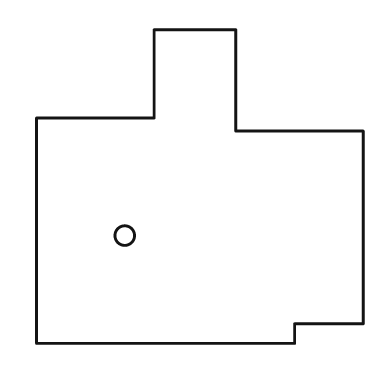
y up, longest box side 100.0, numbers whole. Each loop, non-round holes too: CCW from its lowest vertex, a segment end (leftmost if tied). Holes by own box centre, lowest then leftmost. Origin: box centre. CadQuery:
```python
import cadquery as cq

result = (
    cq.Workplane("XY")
    .moveTo(-50.0, -48.0)
    .lineTo(29.0, -48.0)
    .lineTo(29.0, -42.0)
    .lineTo(50.0, -42.0)
    .lineTo(50.0, 17.0)
    .lineTo(11.0, 17.0)
    .lineTo(11.0, 48.0)
    .lineTo(-14.0, 48.0)
    .lineTo(-14.0, 21.0)
    .lineTo(-50.0, 21.0)
    .close()
    .moveTo(-23.0, -15.0)
    .circle(3.0)
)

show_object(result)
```